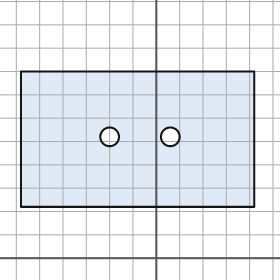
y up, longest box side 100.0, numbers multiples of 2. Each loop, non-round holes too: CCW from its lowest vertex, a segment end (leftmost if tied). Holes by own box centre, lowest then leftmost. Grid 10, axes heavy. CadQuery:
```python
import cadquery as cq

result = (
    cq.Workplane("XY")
    .moveTo(-58.0, 22.0)
    .lineTo(42.0, 22.0)
    .lineTo(42.0, 80.0)
    .lineTo(-58.0, 80.0)
    .close()
    .moveTo(-20.0, 52.0)
    .circle(4.0)
    .moveTo(6.0, 52.0)
    .circle(4.0)
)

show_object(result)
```